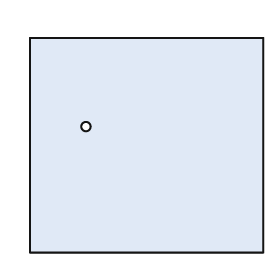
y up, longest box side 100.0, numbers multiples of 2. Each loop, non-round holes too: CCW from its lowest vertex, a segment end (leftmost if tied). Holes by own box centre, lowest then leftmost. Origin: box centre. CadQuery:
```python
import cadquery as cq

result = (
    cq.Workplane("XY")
    .moveTo(-50.0, -46.0)
    .lineTo(50.0, -46.0)
    .lineTo(50.0, 46.0)
    .lineTo(-50.0, 46.0)
    .close()
    .moveTo(-26.0, 8.0)
    .circle(2.0)
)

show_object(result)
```